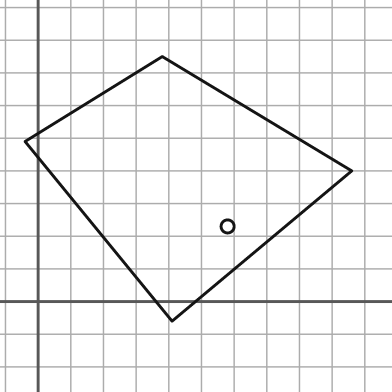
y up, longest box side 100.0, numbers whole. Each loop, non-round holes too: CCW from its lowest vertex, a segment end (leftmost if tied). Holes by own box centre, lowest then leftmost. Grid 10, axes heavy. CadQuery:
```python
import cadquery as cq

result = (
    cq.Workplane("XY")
    .moveTo(41.0, -6.0)
    .lineTo(96.0, 40.0)
    .lineTo(38.0, 75.0)
    .lineTo(-4.0, 49.0)
    .close()
    .moveTo(58.0, 23.0)
    .circle(2.0)
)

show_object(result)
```